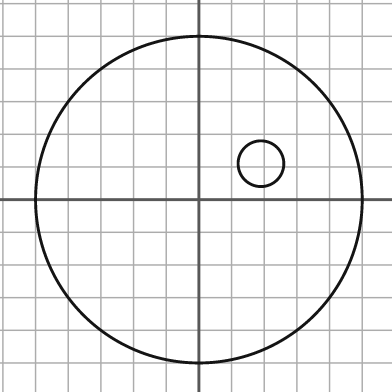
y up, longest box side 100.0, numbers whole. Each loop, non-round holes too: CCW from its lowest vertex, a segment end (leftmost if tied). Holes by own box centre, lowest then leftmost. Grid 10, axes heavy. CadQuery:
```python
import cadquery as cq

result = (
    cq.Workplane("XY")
    .moveTo(0.0, 0.0)
    .circle(50.0)
    .moveTo(19.0, 11.0)
    .circle(7.0)
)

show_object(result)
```